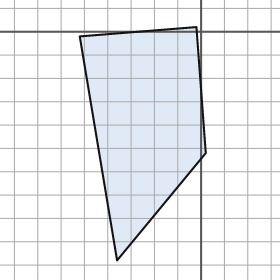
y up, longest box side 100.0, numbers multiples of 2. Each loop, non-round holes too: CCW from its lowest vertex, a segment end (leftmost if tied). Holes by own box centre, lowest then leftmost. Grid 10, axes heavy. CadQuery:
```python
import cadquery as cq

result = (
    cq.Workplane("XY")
    .moveTo(-36.0, -98.0)
    .lineTo(2.0, -52.0)
    .lineTo(-2.0, 2.0)
    .lineTo(-52.0, -2.0)
    .close()
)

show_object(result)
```